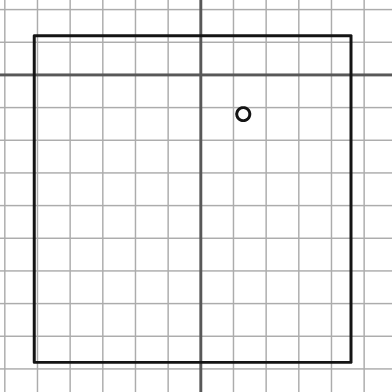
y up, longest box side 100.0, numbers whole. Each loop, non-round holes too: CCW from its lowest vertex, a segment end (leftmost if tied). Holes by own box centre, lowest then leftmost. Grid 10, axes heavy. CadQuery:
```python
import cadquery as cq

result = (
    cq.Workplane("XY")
    .moveTo(-51.0, -88.0)
    .lineTo(46.0, -88.0)
    .lineTo(46.0, 12.0)
    .lineTo(-51.0, 12.0)
    .close()
    .moveTo(13.0, -12.0)
    .circle(2.0)
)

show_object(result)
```